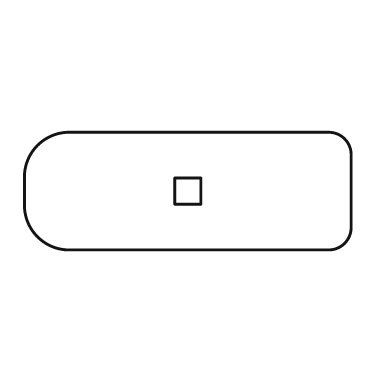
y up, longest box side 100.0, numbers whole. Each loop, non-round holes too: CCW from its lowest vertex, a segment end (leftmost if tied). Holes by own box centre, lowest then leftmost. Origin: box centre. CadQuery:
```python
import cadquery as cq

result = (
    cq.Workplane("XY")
    .moveTo(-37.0, -18.0)
    .lineTo(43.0, -18.0)
    .threePointArc((48.0, -16.0), (50.0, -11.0))
    .lineTo(50.0, 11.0)
    .threePointArc((48.0, 16.0), (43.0, 18.0))
    .lineTo(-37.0, 18.0)
    .threePointArc((-46.0, 14.0), (-50.0, 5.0))
    .lineTo(-50.0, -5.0)
    .threePointArc((-46.0, -14.0), (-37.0, -18.0))
    .close()
    .moveTo(-4.0, -4.0)
    .lineTo(4.0, -4.0)
    .lineTo(4.0, 4.0)
    .lineTo(-4.0, 4.0)
    .close()
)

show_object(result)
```